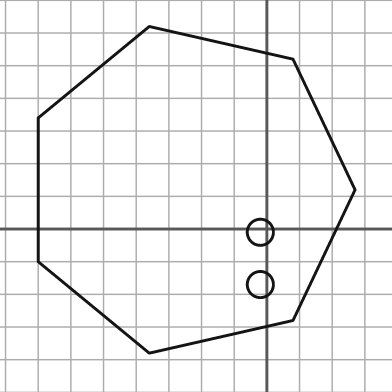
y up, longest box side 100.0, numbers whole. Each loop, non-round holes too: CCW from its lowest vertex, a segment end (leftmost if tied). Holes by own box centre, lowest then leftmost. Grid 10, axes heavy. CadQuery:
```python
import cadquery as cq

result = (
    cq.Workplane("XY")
    .moveTo(-36.0, -38.0)
    .lineTo(8.0, -28.0)
    .lineTo(27.0, 12.0)
    .lineTo(8.0, 52.0)
    .lineTo(-36.0, 62.0)
    .lineTo(-70.0, 34.0)
    .lineTo(-70.0, -10.0)
    .close()
    .moveTo(-2.0, -17.0)
    .circle(4.0)
    .moveTo(-2.0, -1.0)
    .circle(4.0)
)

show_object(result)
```